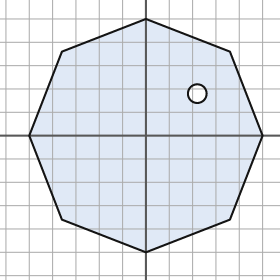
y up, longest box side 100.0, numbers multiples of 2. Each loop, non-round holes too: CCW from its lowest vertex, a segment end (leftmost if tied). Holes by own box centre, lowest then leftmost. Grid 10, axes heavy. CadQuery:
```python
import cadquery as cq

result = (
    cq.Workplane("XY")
    .moveTo(0.0, -50.0)
    .lineTo(36.0, -36.0)
    .lineTo(50.0, 0.0)
    .lineTo(36.0, 36.0)
    .lineTo(0.0, 50.0)
    .lineTo(-36.0, 36.0)
    .lineTo(-50.0, 0.0)
    .lineTo(-36.0, -36.0)
    .close()
    .moveTo(22.0, 18.0)
    .circle(4.0)
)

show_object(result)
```